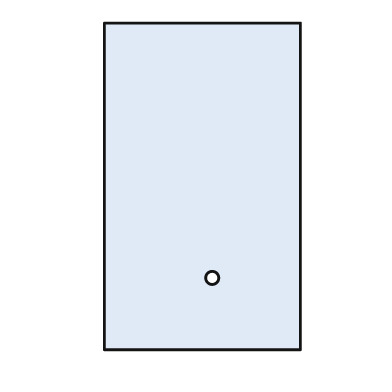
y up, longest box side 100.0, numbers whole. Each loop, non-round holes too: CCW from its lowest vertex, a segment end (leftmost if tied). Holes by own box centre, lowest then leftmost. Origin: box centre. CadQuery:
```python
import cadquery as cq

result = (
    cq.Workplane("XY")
    .moveTo(-30.0, -50.0)
    .lineTo(30.0, -50.0)
    .lineTo(30.0, 50.0)
    .lineTo(-30.0, 50.0)
    .close()
    .moveTo(3.0, -28.0)
    .circle(2.0)
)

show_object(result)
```